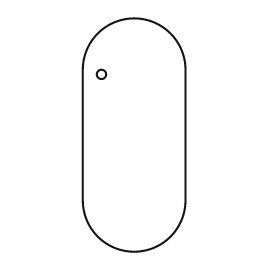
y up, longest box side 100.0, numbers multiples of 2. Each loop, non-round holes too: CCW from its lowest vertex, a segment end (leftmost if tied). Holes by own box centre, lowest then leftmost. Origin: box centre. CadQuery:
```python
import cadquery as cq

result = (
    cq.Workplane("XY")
    .moveTo(-22.0, -28.0)
    .threePointArc((0.0, -50.0), (22.0, -28.0))
    .lineTo(22.0, 28.0)
    .threePointArc((0.0, 50.0), (-22.0, 28.0))
    .close()
    .moveTo(-14.0, 26.0)
    .circle(2.0)
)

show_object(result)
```